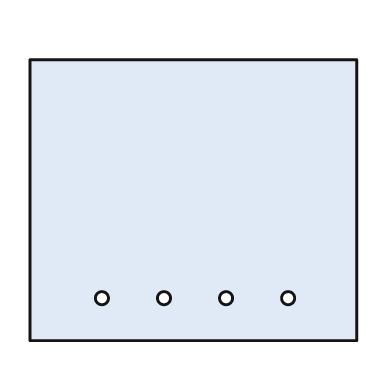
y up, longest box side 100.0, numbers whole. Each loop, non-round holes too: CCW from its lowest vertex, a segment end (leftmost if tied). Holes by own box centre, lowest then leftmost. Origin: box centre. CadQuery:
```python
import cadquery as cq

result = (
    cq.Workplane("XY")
    .moveTo(-50.0, -43.0)
    .lineTo(50.0, -43.0)
    .lineTo(50.0, 43.0)
    .lineTo(-50.0, 43.0)
    .close()
    .moveTo(-28.0, -30.0)
    .circle(2.0)
    .moveTo(-9.0, -30.0)
    .circle(2.0)
    .moveTo(10.0, -30.0)
    .circle(2.0)
    .moveTo(29.0, -30.0)
    .circle(2.0)
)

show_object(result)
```